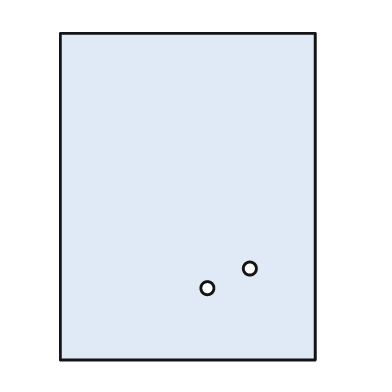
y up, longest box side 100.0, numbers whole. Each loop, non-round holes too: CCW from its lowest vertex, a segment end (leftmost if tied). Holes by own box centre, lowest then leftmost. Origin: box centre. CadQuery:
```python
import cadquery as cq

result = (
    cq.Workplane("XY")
    .moveTo(-39.0, -50.0)
    .lineTo(39.0, -50.0)
    .lineTo(39.0, 50.0)
    .lineTo(-39.0, 50.0)
    .close()
    .moveTo(6.0, -28.0)
    .circle(2.0)
    .moveTo(19.0, -22.0)
    .circle(2.0)
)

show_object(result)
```